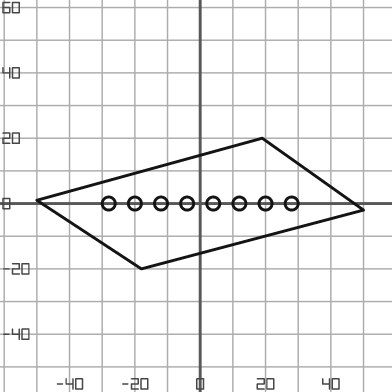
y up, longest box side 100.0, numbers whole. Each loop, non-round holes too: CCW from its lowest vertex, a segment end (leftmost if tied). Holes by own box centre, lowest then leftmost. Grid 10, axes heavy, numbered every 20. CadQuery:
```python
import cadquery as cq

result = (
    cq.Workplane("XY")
    .moveTo(-18.0, -20.0)
    .lineTo(50.0, -2.0)
    .lineTo(19.0, 20.0)
    .lineTo(-50.0, 1.0)
    .close()
    .moveTo(-28.0, 0.0)
    .circle(2.0)
    .moveTo(-20.0, 0.0)
    .circle(2.0)
    .moveTo(-12.0, 0.0)
    .circle(2.0)
    .moveTo(-4.0, 0.0)
    .circle(2.0)
    .moveTo(4.0, 0.0)
    .circle(2.0)
    .moveTo(12.0, 0.0)
    .circle(2.0)
    .moveTo(20.0, 0.0)
    .circle(2.0)
    .moveTo(28.0, 0.0)
    .circle(2.0)
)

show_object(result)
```